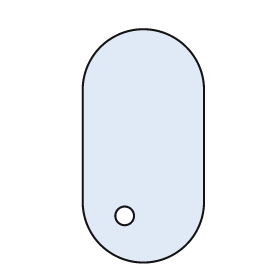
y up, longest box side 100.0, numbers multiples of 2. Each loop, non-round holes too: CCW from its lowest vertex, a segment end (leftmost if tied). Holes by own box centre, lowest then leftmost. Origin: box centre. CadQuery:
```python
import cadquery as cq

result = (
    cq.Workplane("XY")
    .moveTo(-26.0, -24.0)
    .threePointArc((0.0, -50.0), (26.0, -24.0))
    .lineTo(26.0, 24.0)
    .threePointArc((0.0, 50.0), (-26.0, 24.0))
    .close()
    .moveTo(-8.0, -30.0)
    .circle(4.0)
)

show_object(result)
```